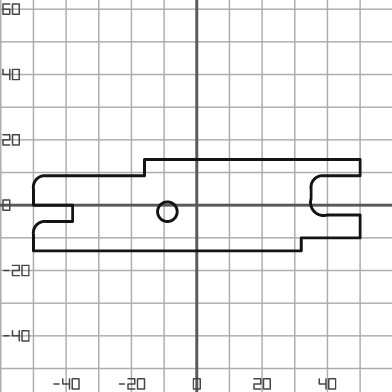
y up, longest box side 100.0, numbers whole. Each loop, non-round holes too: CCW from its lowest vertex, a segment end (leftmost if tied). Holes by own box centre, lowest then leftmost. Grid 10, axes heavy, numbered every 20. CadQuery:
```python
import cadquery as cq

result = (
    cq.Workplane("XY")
    .moveTo(-50.0, -14.0)
    .lineTo(32.0, -14.0)
    .lineTo(32.0, -10.0)
    .lineTo(50.0, -10.0)
    .lineTo(50.0, -3.0)
    .lineTo(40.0, -3.0)
    .threePointArc((36.0, -2.0), (35.0, 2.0))
    .lineTo(35.0, 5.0)
    .threePointArc((36.0, 8.0), (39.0, 9.0))
    .lineTo(50.0, 9.0)
    .lineTo(50.0, 14.0)
    .lineTo(-16.0, 14.0)
    .lineTo(-16.0, 9.0)
    .lineTo(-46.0, 9.0)
    .threePointArc((-49.0, 8.0), (-50.0, 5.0))
    .lineTo(-50.0, 0.0)
    .lineTo(-38.0, 0.0)
    .lineTo(-38.0, -5.0)
    .lineTo(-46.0, -5.0)
    .threePointArc((-49.0, -6.0), (-50.0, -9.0))
    .close()
    .moveTo(-9.0, -2.0)
    .circle(3.0)
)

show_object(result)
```